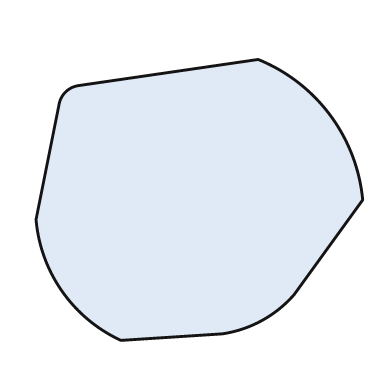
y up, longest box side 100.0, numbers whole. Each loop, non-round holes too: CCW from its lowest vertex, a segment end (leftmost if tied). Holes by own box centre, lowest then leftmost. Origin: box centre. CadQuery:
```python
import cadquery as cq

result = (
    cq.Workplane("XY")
    .moveTo(-24.0, -43.0)
    .lineTo(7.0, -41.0)
    .threePointArc((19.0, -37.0), (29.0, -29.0))
    .lineTo(50.0, 0.0)
    .threePointArc((40.0, 26.0), (18.0, 43.0))
    .lineTo(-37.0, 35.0)
    .threePointArc((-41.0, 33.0), (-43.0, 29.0))
    .lineTo(-50.0, -6.0)
    .threePointArc((-42.0, -28.0), (-24.0, -43.0))
    .close()
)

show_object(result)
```